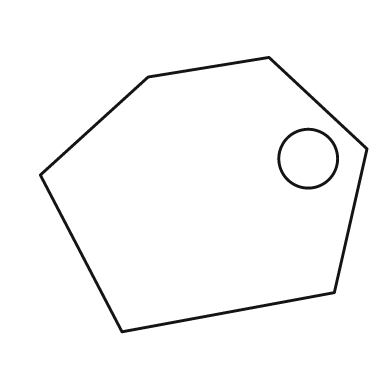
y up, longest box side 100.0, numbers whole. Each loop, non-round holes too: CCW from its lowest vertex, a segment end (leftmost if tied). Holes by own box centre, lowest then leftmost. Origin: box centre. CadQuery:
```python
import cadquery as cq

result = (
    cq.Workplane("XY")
    .moveTo(-25.0, -42.0)
    .lineTo(40.0, -30.0)
    .lineTo(50.0, 14.0)
    .lineTo(20.0, 42.0)
    .lineTo(-17.0, 36.0)
    .lineTo(-50.0, 6.0)
    .close()
    .moveTo(32.0, 11.0)
    .circle(9.0)
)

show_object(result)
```